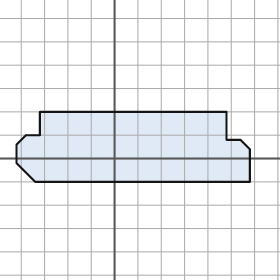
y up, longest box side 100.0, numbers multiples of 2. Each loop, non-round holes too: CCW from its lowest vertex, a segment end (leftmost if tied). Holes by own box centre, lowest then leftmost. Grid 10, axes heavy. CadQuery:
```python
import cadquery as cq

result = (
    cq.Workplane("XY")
    .moveTo(-34.0, -10.0)
    .lineTo(58.0, -10.0)
    .lineTo(58.0, 4.0)
    .lineTo(54.0, 8.0)
    .lineTo(48.0, 8.0)
    .lineTo(48.0, 20.0)
    .lineTo(-32.0, 20.0)
    .lineTo(-32.0, 10.0)
    .lineTo(-38.0, 10.0)
    .lineTo(-42.0, 6.0)
    .lineTo(-42.0, -2.0)
    .close()
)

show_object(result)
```